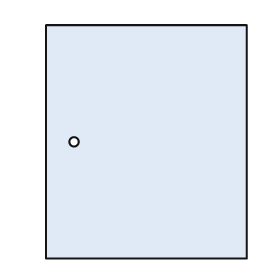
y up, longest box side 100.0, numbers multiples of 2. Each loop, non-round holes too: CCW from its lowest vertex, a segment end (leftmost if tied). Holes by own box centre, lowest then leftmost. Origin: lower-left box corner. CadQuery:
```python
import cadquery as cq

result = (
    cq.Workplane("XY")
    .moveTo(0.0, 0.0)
    .lineTo(86.0, 0.0)
    .lineTo(86.0, 100.0)
    .lineTo(0.0, 100.0)
    .close()
    .moveTo(12.0, 50.0)
    .circle(2.0)
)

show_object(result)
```